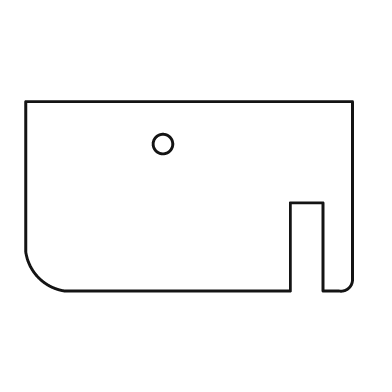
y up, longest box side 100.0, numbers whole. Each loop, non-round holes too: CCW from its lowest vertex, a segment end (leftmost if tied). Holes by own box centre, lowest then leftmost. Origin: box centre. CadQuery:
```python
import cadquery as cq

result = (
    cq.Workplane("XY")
    .moveTo(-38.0, -29.0)
    .lineTo(31.0, -29.0)
    .lineTo(31.0, -2.0)
    .lineTo(41.0, -2.0)
    .lineTo(41.0, -29.0)
    .lineTo(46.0, -29.0)
    .threePointArc((49.0, -28.0), (50.0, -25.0))
    .lineTo(50.0, 29.0)
    .lineTo(-50.0, 29.0)
    .lineTo(-50.0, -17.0)
    .threePointArc((-46.0, -25.0), (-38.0, -29.0))
    .close()
    .moveTo(-8.0, 16.0)
    .circle(3.0)
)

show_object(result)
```